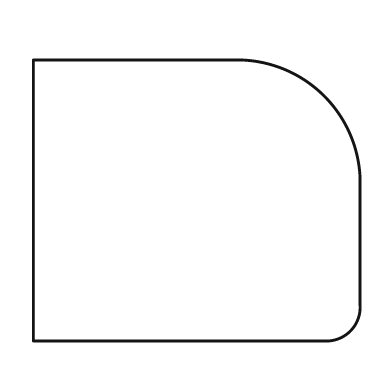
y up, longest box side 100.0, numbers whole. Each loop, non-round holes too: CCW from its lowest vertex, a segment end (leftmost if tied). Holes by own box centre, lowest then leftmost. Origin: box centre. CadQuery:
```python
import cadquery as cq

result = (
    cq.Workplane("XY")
    .moveTo(-50.0, -43.0)
    .lineTo(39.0, -43.0)
    .threePointArc((47.0, -40.0), (50.0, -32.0))
    .lineTo(50.0, 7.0)
    .threePointArc((39.0, 32.0), (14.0, 43.0))
    .lineTo(-50.0, 43.0)
    .close()
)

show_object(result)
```